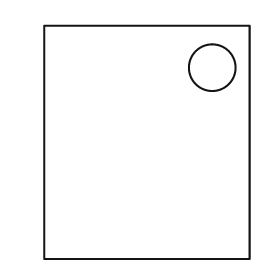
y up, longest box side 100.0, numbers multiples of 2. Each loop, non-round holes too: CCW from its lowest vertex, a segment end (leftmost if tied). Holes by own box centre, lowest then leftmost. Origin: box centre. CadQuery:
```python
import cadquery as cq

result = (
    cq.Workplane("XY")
    .moveTo(-44.0, -50.0)
    .lineTo(44.0, -50.0)
    .lineTo(44.0, 50.0)
    .lineTo(-44.0, 50.0)
    .close()
    .moveTo(28.0, 32.0)
    .circle(10.0)
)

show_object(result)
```